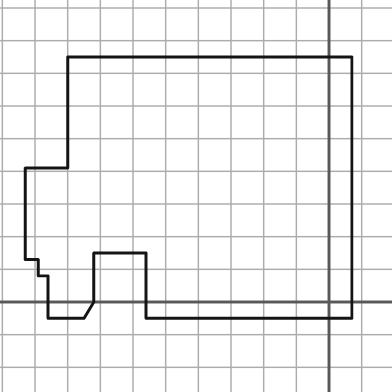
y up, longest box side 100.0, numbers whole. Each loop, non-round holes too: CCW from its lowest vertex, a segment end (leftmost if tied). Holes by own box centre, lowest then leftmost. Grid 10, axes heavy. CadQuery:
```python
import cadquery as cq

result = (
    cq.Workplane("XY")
    .moveTo(-86.0, -5.0)
    .lineTo(-75.0, -5.0)
    .lineTo(-72.0, 0.0)
    .lineTo(-72.0, 15.0)
    .lineTo(-56.0, 15.0)
    .lineTo(-56.0, -5.0)
    .lineTo(7.0, -5.0)
    .lineTo(7.0, 75.0)
    .lineTo(-80.0, 75.0)
    .lineTo(-80.0, 41.0)
    .lineTo(-93.0, 41.0)
    .lineTo(-93.0, 13.0)
    .lineTo(-89.0, 13.0)
    .lineTo(-89.0, 8.0)
    .lineTo(-86.0, 8.0)
    .close()
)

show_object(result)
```